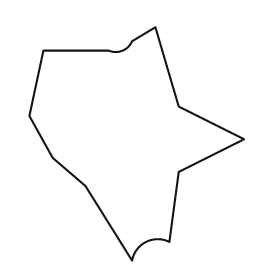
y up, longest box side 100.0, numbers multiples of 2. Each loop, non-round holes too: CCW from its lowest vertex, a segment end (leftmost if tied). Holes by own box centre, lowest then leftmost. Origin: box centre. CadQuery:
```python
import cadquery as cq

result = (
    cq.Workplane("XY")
    .moveTo(-2.0, -50.0)
    .threePointArc((4.0, -42.0), (14.0, -42.0))
    .lineTo(18.0, -12.0)
    .lineTo(46.0, 2.0)
    .lineTo(18.0, 16.0)
    .lineTo(8.0, 50.0)
    .lineTo(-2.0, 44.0)
    .threePointArc((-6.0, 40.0), (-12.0, 40.0))
    .lineTo(-40.0, 40.0)
    .lineTo(-46.0, 12.0)
    .lineTo(-36.0, -6.0)
    .lineTo(-22.0, -18.0)
    .close()
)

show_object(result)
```